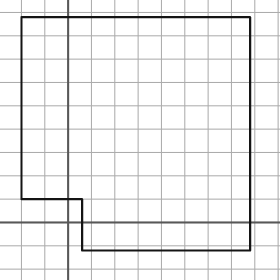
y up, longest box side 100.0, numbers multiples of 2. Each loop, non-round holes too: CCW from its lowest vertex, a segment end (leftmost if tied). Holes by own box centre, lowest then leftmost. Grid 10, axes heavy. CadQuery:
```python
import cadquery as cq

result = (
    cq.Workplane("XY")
    .moveTo(6.0, -12.0)
    .lineTo(78.0, -12.0)
    .lineTo(78.0, 88.0)
    .lineTo(-20.0, 88.0)
    .lineTo(-20.0, 10.0)
    .lineTo(6.0, 10.0)
    .close()
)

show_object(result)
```